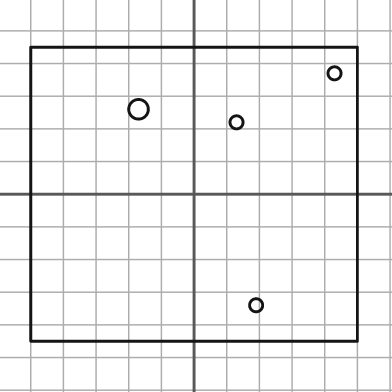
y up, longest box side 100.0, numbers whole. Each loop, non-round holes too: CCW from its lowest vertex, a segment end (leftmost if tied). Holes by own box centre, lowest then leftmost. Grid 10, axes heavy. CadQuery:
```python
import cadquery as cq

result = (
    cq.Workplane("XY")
    .moveTo(-50.0, -45.0)
    .lineTo(50.0, -45.0)
    .lineTo(50.0, 45.0)
    .lineTo(-50.0, 45.0)
    .close()
    .moveTo(19.0, -34.0)
    .circle(2.0)
    .moveTo(13.0, 22.0)
    .circle(2.0)
    .moveTo(-17.0, 26.0)
    .circle(3.0)
    .moveTo(43.0, 37.0)
    .circle(2.0)
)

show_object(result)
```